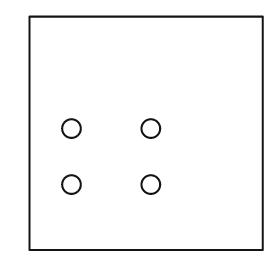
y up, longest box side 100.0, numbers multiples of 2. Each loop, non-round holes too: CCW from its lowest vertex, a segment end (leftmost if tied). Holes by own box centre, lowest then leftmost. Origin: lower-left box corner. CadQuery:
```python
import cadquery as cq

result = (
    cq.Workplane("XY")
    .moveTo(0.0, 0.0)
    .lineTo(100.0, 0.0)
    .lineTo(100.0, 100.0)
    .lineTo(0.0, 100.0)
    .close()
    .moveTo(18.0, 28.0)
    .circle(4.0)
    .moveTo(52.0, 28.0)
    .circle(4.0)
    .moveTo(18.0, 52.0)
    .circle(4.0)
    .moveTo(52.0, 52.0)
    .circle(4.0)
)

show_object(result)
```